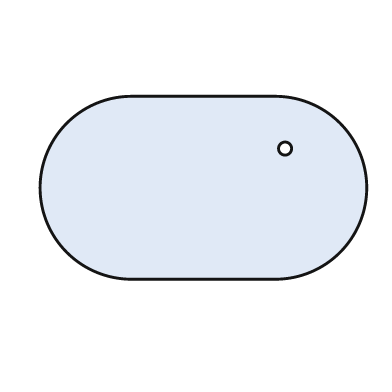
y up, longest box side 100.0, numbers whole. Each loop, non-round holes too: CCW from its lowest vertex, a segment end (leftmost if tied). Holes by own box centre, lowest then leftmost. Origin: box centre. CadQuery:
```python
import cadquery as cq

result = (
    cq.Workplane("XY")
    .moveTo(-22.0, -28.0)
    .lineTo(22.0, -28.0)
    .threePointArc((50.0, 0.0), (22.0, 28.0))
    .lineTo(-22.0, 28.0)
    .threePointArc((-50.0, 0.0), (-22.0, -28.0))
    .close()
    .moveTo(25.0, 12.0)
    .circle(2.0)
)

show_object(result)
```